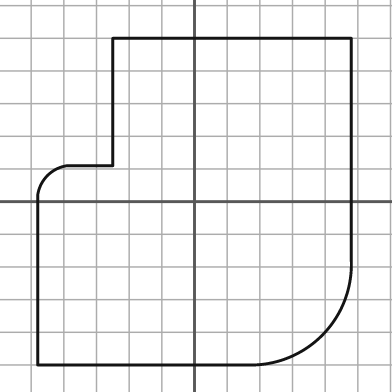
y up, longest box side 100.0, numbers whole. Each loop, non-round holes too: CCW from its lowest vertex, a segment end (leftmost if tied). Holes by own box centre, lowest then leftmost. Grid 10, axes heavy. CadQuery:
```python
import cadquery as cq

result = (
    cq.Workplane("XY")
    .moveTo(-48.0, -50.0)
    .lineTo(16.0, -50.0)
    .threePointArc((39.0, -41.0), (48.0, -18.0))
    .lineTo(48.0, 50.0)
    .lineTo(-25.0, 50.0)
    .lineTo(-25.0, 11.0)
    .lineTo(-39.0, 11.0)
    .threePointArc((-45.0, 8.0), (-48.0, 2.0))
    .close()
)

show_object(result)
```